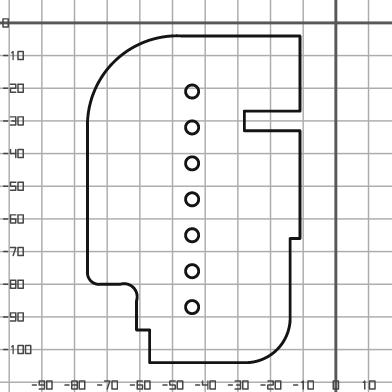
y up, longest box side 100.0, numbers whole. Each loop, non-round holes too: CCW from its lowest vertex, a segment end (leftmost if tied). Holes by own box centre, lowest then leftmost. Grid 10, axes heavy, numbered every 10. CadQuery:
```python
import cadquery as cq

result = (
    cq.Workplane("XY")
    .moveTo(-57.0, -104.0)
    .lineTo(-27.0, -104.0)
    .threePointArc((-18.0, -100.0), (-14.0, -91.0))
    .lineTo(-14.0, -66.0)
    .lineTo(-11.0, -66.0)
    .lineTo(-11.0, -33.0)
    .lineTo(-28.0, -33.0)
    .lineTo(-28.0, -27.0)
    .lineTo(-11.0, -27.0)
    .lineTo(-11.0, -4.0)
    .lineTo(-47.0, -4.0)
    .threePointArc((-68.0, -12.0), (-76.0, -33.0))
    .lineTo(-76.0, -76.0)
    .threePointArc((-75.0, -79.0), (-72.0, -80.0))
    .lineTo(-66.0, -80.0)
    .threePointArc((-62.0, -81.0), (-61.0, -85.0))
    .lineTo(-61.0, -94.0)
    .lineTo(-57.0, -94.0)
    .close()
    .moveTo(-44.0, -87.0)
    .circle(2.0)
    .moveTo(-44.0, -76.0)
    .circle(2.0)
    .moveTo(-44.0, -65.0)
    .circle(2.0)
    .moveTo(-44.0, -54.0)
    .circle(2.0)
    .moveTo(-44.0, -43.0)
    .circle(2.0)
    .moveTo(-44.0, -32.0)
    .circle(2.0)
    .moveTo(-44.0, -21.0)
    .circle(2.0)
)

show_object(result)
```